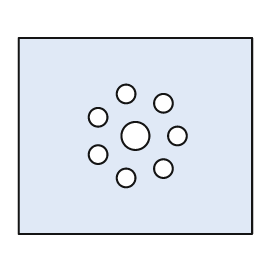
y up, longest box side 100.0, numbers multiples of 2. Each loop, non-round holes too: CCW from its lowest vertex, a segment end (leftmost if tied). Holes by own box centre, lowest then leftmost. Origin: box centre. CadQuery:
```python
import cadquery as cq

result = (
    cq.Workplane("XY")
    .moveTo(-50.0, -42.0)
    .lineTo(50.0, -42.0)
    .lineTo(50.0, 42.0)
    .lineTo(-50.0, 42.0)
    .close()
    .moveTo(-4.0, -18.0)
    .circle(4.0)
    .moveTo(12.0, -14.0)
    .circle(4.0)
    .moveTo(-16.0, -8.0)
    .circle(4.0)
    .moveTo(0.0, 0.0)
    .circle(6.0)
    .moveTo(18.0, 0.0)
    .circle(4.0)
    .moveTo(-16.0, 8.0)
    .circle(4.0)
    .moveTo(12.0, 14.0)
    .circle(4.0)
    .moveTo(-4.0, 18.0)
    .circle(4.0)
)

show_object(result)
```